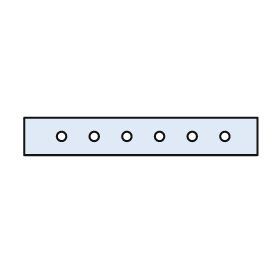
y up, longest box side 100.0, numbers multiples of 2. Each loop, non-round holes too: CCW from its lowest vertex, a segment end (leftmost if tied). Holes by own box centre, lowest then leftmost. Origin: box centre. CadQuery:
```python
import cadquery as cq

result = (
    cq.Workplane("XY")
    .moveTo(-50.0, -8.0)
    .lineTo(50.0, -8.0)
    .lineTo(50.0, 8.0)
    .lineTo(-50.0, 8.0)
    .close()
    .moveTo(-34.0, 0.0)
    .circle(2.0)
    .moveTo(-20.0, 0.0)
    .circle(2.0)
    .moveTo(-6.0, 0.0)
    .circle(2.0)
    .moveTo(8.0, 0.0)
    .circle(2.0)
    .moveTo(22.0, 0.0)
    .circle(2.0)
    .moveTo(36.0, 0.0)
    .circle(2.0)
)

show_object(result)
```